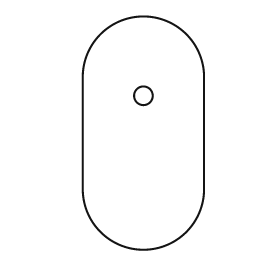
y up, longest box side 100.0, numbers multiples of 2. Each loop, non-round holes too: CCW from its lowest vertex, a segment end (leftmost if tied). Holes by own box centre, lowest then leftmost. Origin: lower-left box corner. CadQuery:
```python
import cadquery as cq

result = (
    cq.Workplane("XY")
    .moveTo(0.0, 26.0)
    .threePointArc((26.0, 0.0), (52.0, 26.0))
    .lineTo(52.0, 74.0)
    .threePointArc((26.0, 100.0), (0.0, 74.0))
    .close()
    .moveTo(26.0, 66.0)
    .circle(4.0)
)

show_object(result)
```